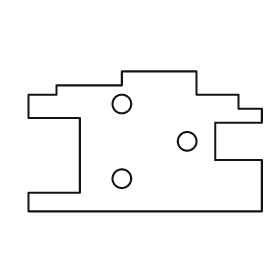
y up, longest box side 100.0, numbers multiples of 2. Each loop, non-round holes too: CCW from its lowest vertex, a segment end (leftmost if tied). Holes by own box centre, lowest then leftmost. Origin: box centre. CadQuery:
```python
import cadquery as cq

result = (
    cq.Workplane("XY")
    .moveTo(-50.0, -30.0)
    .lineTo(50.0, -30.0)
    .lineTo(50.0, -8.0)
    .lineTo(30.0, -8.0)
    .lineTo(30.0, 8.0)
    .lineTo(50.0, 8.0)
    .lineTo(50.0, 14.0)
    .lineTo(40.0, 14.0)
    .lineTo(40.0, 20.0)
    .lineTo(22.0, 20.0)
    .lineTo(22.0, 30.0)
    .lineTo(-10.0, 30.0)
    .lineTo(-10.0, 24.0)
    .lineTo(-38.0, 24.0)
    .lineTo(-38.0, 20.0)
    .lineTo(-50.0, 20.0)
    .lineTo(-50.0, 10.0)
    .lineTo(-28.0, 10.0)
    .lineTo(-28.0, -22.0)
    .lineTo(-50.0, -22.0)
    .close()
    .moveTo(-10.0, -16.0)
    .circle(4.0)
    .moveTo(18.0, 0.0)
    .circle(4.0)
    .moveTo(-10.0, 16.0)
    .circle(4.0)
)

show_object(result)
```